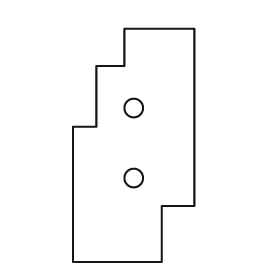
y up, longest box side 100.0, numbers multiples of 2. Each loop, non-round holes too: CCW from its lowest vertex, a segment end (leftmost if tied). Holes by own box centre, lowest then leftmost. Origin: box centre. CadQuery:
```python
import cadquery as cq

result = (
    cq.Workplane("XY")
    .moveTo(-26.0, -50.0)
    .lineTo(12.0, -50.0)
    .lineTo(12.0, -26.0)
    .lineTo(26.0, -26.0)
    .lineTo(26.0, 50.0)
    .lineTo(-4.0, 50.0)
    .lineTo(-4.0, 34.0)
    .lineTo(-16.0, 34.0)
    .lineTo(-16.0, 8.0)
    .lineTo(-26.0, 8.0)
    .close()
    .moveTo(0.0, -14.0)
    .circle(4.0)
    .moveTo(0.0, 16.0)
    .circle(4.0)
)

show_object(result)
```